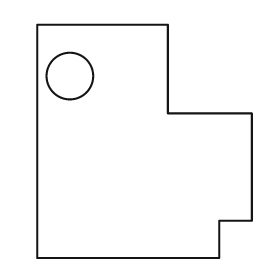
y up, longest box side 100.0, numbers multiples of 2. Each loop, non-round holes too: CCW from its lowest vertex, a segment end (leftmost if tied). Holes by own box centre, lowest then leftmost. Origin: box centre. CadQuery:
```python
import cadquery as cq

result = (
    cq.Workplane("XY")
    .moveTo(-46.0, -50.0)
    .lineTo(32.0, -50.0)
    .lineTo(32.0, -34.0)
    .lineTo(46.0, -34.0)
    .lineTo(46.0, 12.0)
    .lineTo(10.0, 12.0)
    .lineTo(10.0, 50.0)
    .lineTo(-46.0, 50.0)
    .close()
    .moveTo(-32.0, 28.0)
    .circle(10.0)
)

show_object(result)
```